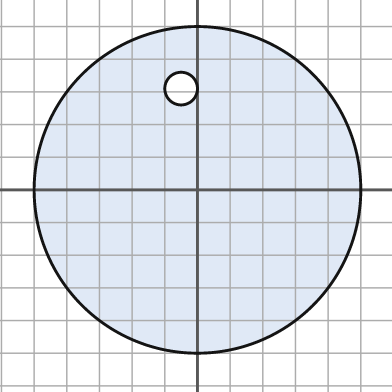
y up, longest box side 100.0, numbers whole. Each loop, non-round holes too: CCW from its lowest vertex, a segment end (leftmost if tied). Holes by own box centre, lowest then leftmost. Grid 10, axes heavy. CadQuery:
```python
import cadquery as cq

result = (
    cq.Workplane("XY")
    .moveTo(0.0, 0.0)
    .circle(50.0)
    .moveTo(-5.0, 31.0)
    .circle(5.0)
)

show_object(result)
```